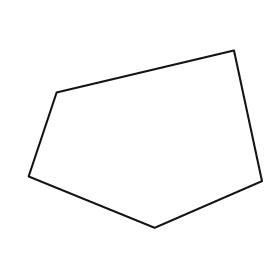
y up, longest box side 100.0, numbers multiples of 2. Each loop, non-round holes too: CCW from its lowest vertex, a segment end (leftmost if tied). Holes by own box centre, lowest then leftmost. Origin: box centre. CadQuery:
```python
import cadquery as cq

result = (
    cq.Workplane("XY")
    .moveTo(4.0, -38.0)
    .lineTo(50.0, -18.0)
    .lineTo(38.0, 38.0)
    .lineTo(-38.0, 20.0)
    .lineTo(-50.0, -16.0)
    .close()
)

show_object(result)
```